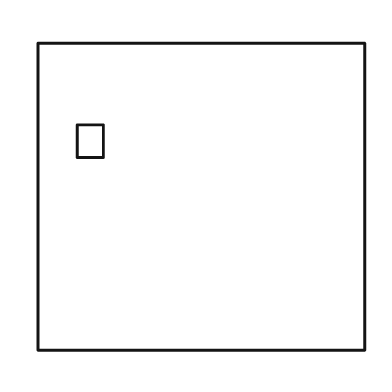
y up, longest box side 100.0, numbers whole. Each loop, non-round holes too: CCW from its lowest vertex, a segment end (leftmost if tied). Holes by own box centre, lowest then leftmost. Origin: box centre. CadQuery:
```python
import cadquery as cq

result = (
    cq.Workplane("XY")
    .moveTo(-50.0, -47.0)
    .lineTo(50.0, -47.0)
    .lineTo(50.0, 47.0)
    .lineTo(-50.0, 47.0)
    .close()
    .moveTo(-38.0, 12.0)
    .lineTo(-30.0, 12.0)
    .lineTo(-30.0, 22.0)
    .lineTo(-38.0, 22.0)
    .close()
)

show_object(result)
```